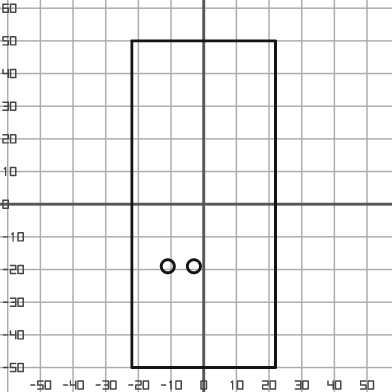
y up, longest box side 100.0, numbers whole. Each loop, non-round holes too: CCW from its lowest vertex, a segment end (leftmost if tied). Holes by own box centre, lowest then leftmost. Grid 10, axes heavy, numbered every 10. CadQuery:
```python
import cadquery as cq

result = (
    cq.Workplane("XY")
    .moveTo(-22.0, -50.0)
    .lineTo(22.0, -50.0)
    .lineTo(22.0, 50.0)
    .lineTo(-22.0, 50.0)
    .close()
    .moveTo(-11.0, -19.0)
    .circle(2.0)
    .moveTo(-3.0, -19.0)
    .circle(2.0)
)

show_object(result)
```